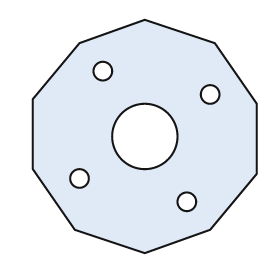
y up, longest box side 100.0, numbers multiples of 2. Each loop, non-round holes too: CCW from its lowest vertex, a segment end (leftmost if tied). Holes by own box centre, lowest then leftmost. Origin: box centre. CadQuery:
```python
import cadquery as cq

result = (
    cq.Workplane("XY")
    .moveTo(0.0, -50.0)
    .lineTo(28.0, -40.0)
    .lineTo(48.0, -16.0)
    .lineTo(48.0, 14.0)
    .lineTo(30.0, 40.0)
    .lineTo(0.0, 50.0)
    .lineTo(-28.0, 40.0)
    .lineTo(-48.0, 16.0)
    .lineTo(-48.0, -14.0)
    .lineTo(-30.0, -40.0)
    .close()
    .moveTo(18.0, -28.0)
    .circle(4.0)
    .moveTo(-28.0, -18.0)
    .circle(4.0)
    .moveTo(0.0, 0.0)
    .circle(14.0)
    .moveTo(28.0, 18.0)
    .circle(4.0)
    .moveTo(-18.0, 28.0)
    .circle(4.0)
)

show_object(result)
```